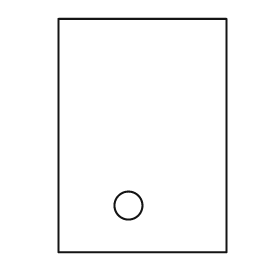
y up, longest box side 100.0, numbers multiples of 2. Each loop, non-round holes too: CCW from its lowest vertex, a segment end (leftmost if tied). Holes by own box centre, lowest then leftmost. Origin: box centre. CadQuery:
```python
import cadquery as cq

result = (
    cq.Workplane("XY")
    .moveTo(-36.0, -50.0)
    .lineTo(36.0, -50.0)
    .lineTo(36.0, 50.0)
    .lineTo(-36.0, 50.0)
    .close()
    .moveTo(-6.0, -30.0)
    .circle(6.0)
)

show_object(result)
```